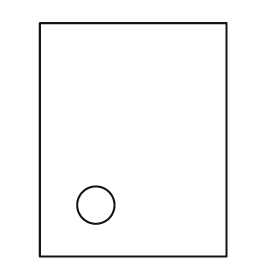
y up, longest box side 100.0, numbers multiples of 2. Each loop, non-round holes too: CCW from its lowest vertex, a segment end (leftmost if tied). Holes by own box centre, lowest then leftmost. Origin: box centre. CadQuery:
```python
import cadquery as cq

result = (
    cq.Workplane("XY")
    .moveTo(-40.0, -50.0)
    .lineTo(40.0, -50.0)
    .lineTo(40.0, 50.0)
    .lineTo(-40.0, 50.0)
    .close()
    .moveTo(-16.0, -28.0)
    .circle(8.0)
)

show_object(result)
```